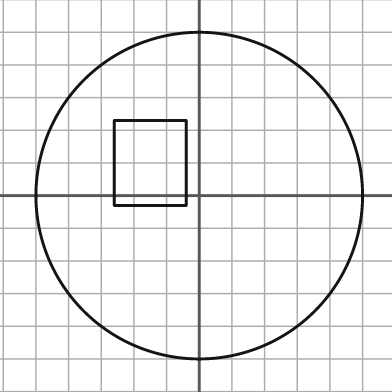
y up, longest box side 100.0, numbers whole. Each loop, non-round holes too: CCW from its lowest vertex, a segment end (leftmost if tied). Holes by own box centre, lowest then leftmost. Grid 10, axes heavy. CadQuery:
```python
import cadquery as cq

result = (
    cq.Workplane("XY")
    .moveTo(0.0, 0.0)
    .circle(50.0)
    .moveTo(-26.0, -3.0)
    .lineTo(-4.0, -3.0)
    .lineTo(-4.0, 23.0)
    .lineTo(-26.0, 23.0)
    .close()
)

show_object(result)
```